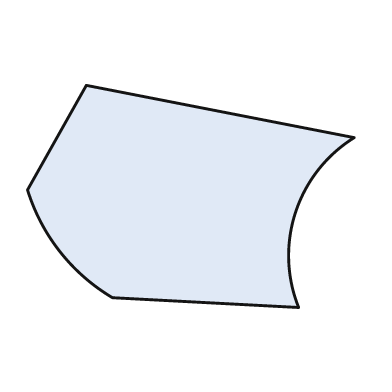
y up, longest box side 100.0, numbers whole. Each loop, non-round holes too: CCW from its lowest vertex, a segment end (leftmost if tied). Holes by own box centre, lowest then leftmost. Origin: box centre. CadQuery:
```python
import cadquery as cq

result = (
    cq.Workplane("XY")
    .moveTo(33.0, -34.0)
    .threePointArc((32.0, -5.0), (50.0, 18.0))
    .lineTo(-32.0, 34.0)
    .lineTo(-50.0, 2.0)
    .threePointArc((-40.0, -17.0), (-24.0, -31.0))
    .close()
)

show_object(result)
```